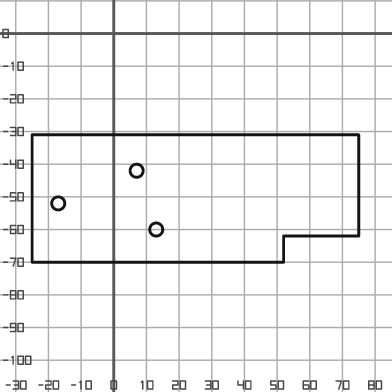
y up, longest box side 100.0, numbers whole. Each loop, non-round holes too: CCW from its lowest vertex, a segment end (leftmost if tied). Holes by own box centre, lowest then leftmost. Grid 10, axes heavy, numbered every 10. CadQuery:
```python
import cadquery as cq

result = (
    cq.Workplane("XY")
    .moveTo(-25.0, -70.0)
    .lineTo(52.0, -70.0)
    .lineTo(52.0, -62.0)
    .lineTo(75.0, -62.0)
    .lineTo(75.0, -31.0)
    .lineTo(-25.0, -31.0)
    .close()
    .moveTo(13.0, -60.0)
    .circle(2.0)
    .moveTo(-17.0, -52.0)
    .circle(2.0)
    .moveTo(7.0, -42.0)
    .circle(2.0)
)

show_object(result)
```